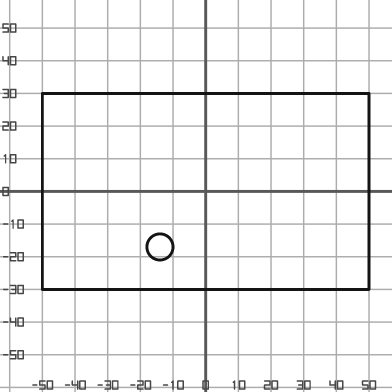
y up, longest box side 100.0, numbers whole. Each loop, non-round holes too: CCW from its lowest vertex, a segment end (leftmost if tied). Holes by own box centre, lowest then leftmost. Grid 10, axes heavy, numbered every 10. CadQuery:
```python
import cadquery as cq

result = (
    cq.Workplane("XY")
    .moveTo(-50.0, -30.0)
    .lineTo(50.0, -30.0)
    .lineTo(50.0, 30.0)
    .lineTo(-50.0, 30.0)
    .close()
    .moveTo(-14.0, -17.0)
    .circle(4.0)
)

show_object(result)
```